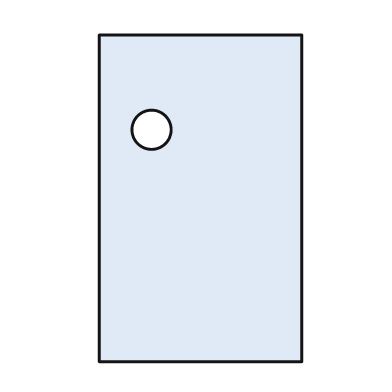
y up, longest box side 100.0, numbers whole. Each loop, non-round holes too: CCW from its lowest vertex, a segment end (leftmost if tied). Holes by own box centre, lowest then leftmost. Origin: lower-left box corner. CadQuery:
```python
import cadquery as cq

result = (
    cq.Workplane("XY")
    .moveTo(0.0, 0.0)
    .lineTo(62.0, 0.0)
    .lineTo(62.0, 100.0)
    .lineTo(0.0, 100.0)
    .close()
    .moveTo(16.0, 71.0)
    .circle(6.0)
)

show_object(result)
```